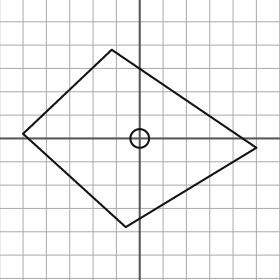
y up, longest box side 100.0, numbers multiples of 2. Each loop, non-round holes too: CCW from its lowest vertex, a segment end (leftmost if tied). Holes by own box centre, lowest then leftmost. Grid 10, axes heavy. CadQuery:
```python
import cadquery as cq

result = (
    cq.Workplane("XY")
    .moveTo(-6.0, -38.0)
    .lineTo(50.0, -4.0)
    .lineTo(-12.0, 38.0)
    .lineTo(-50.0, 2.0)
    .close()
    .moveTo(0.0, 0.0)
    .circle(4.0)
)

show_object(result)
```